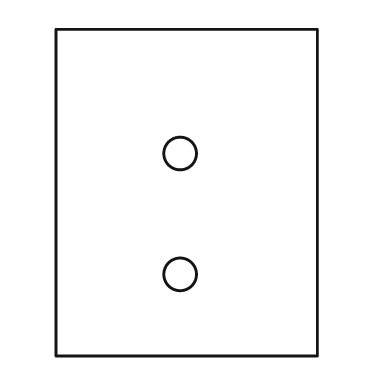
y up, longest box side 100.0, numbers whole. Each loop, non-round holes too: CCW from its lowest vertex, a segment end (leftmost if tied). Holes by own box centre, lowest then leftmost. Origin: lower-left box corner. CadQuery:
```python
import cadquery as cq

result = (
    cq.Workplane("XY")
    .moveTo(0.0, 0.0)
    .lineTo(80.0, 0.0)
    .lineTo(80.0, 100.0)
    .lineTo(0.0, 100.0)
    .close()
    .moveTo(38.0, 25.0)
    .circle(5.0)
    .moveTo(38.0, 62.0)
    .circle(5.0)
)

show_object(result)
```